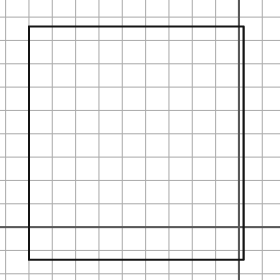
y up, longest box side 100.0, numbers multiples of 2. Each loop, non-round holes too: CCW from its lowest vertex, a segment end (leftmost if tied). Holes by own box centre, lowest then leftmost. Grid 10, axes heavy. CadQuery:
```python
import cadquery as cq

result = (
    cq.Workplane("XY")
    .moveTo(-90.0, -14.0)
    .lineTo(2.0, -14.0)
    .lineTo(2.0, 86.0)
    .lineTo(-90.0, 86.0)
    .close()
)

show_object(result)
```